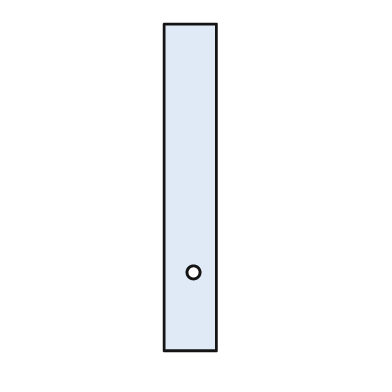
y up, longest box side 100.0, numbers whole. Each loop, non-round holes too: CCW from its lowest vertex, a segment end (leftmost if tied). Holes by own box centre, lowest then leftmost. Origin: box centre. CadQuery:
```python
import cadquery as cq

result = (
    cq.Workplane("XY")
    .moveTo(-8.0, -50.0)
    .lineTo(8.0, -50.0)
    .lineTo(8.0, 50.0)
    .lineTo(-8.0, 50.0)
    .close()
    .moveTo(1.0, -26.0)
    .circle(2.0)
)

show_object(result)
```